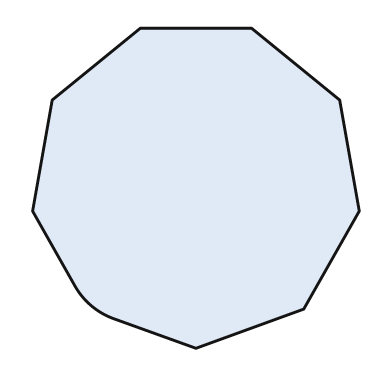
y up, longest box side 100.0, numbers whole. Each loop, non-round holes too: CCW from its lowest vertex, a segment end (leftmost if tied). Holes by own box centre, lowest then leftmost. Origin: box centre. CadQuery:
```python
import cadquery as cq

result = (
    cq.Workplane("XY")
    .moveTo(0.0, -49.0)
    .lineTo(33.0, -37.0)
    .lineTo(50.0, -7.0)
    .lineTo(44.0, 27.0)
    .lineTo(17.0, 49.0)
    .lineTo(-17.0, 49.0)
    .lineTo(-44.0, 27.0)
    .lineTo(-50.0, -7.0)
    .lineTo(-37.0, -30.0)
    .threePointArc((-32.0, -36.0), (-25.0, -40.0))
    .close()
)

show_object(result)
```